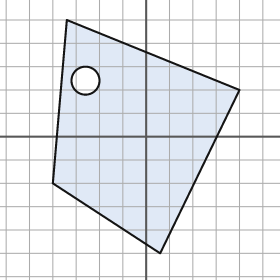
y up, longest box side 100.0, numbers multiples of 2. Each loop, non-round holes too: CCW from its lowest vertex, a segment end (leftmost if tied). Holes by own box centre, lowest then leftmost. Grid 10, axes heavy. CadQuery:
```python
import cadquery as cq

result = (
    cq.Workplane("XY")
    .moveTo(6.0, -50.0)
    .lineTo(40.0, 20.0)
    .lineTo(-34.0, 50.0)
    .lineTo(-40.0, -20.0)
    .close()
    .moveTo(-26.0, 24.0)
    .circle(6.0)
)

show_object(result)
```